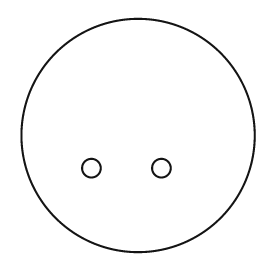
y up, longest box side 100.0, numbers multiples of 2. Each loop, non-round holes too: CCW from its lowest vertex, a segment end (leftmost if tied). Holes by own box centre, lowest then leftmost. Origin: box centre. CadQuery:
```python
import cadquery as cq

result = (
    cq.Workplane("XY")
    .moveTo(0.0, 0.0)
    .circle(50.0)
    .moveTo(-20.0, -14.0)
    .circle(4.0)
    .moveTo(10.0, -14.0)
    .circle(4.0)
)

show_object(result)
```